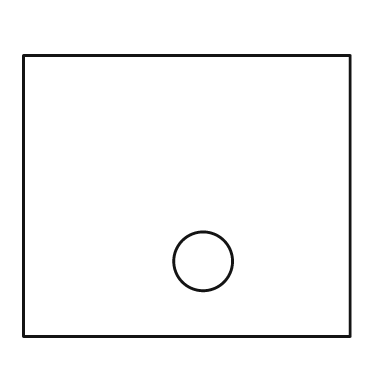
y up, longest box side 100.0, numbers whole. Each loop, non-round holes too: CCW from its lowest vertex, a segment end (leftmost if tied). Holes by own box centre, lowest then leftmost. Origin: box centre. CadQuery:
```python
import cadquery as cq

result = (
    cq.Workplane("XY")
    .moveTo(-50.0, -43.0)
    .lineTo(50.0, -43.0)
    .lineTo(50.0, 43.0)
    .lineTo(-50.0, 43.0)
    .close()
    .moveTo(5.0, -20.0)
    .circle(9.0)
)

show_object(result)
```